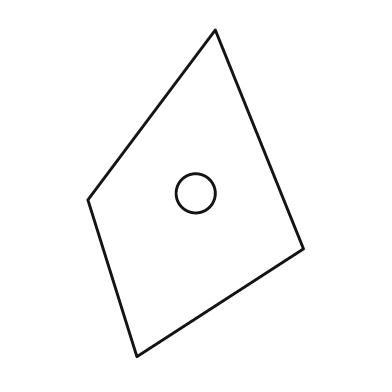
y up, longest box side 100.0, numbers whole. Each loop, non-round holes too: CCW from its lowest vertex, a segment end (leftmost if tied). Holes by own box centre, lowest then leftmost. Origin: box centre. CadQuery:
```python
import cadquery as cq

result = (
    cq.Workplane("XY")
    .moveTo(-18.0, -50.0)
    .lineTo(33.0, -17.0)
    .lineTo(6.0, 50.0)
    .lineTo(-33.0, -2.0)
    .close()
    .moveTo(0.0, 0.0)
    .circle(6.0)
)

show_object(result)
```